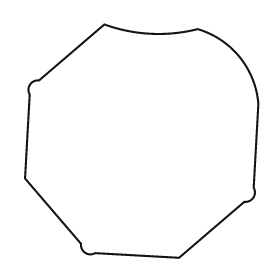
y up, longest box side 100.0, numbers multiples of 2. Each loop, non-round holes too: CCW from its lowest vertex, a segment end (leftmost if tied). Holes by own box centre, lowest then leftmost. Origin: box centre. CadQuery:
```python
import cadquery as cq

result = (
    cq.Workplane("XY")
    .moveTo(16.0, -50.0)
    .lineTo(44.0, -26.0)
    .threePointArc((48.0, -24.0), (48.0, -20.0))
    .lineTo(50.0, 16.0)
    .threePointArc((42.0, 36.0), (24.0, 48.0))
    .threePointArc((4.0, 46.0), (-16.0, 50.0))
    .lineTo(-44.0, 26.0)
    .threePointArc((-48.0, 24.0), (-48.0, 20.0))
    .lineTo(-50.0, -16.0)
    .lineTo(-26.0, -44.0)
    .threePointArc((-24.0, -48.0), (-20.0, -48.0))
    .close()
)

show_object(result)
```